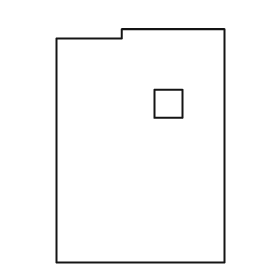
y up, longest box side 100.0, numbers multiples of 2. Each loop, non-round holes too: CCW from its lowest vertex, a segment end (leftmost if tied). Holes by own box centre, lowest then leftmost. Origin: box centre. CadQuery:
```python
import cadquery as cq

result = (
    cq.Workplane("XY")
    .moveTo(-36.0, -50.0)
    .lineTo(36.0, -50.0)
    .lineTo(36.0, 50.0)
    .lineTo(-8.0, 50.0)
    .lineTo(-8.0, 46.0)
    .lineTo(-36.0, 46.0)
    .close()
    .moveTo(6.0, 12.0)
    .lineTo(18.0, 12.0)
    .lineTo(18.0, 24.0)
    .lineTo(6.0, 24.0)
    .close()
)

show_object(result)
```